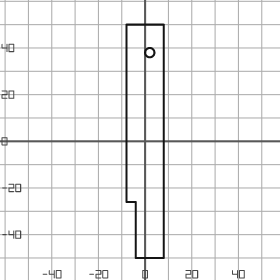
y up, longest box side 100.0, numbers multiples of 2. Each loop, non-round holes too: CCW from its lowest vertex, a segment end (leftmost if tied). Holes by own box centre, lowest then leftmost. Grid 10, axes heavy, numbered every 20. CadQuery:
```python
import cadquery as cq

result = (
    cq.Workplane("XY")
    .moveTo(-4.0, -50.0)
    .lineTo(8.0, -50.0)
    .lineTo(8.0, 50.0)
    .lineTo(-8.0, 50.0)
    .lineTo(-8.0, -26.0)
    .lineTo(-4.0, -26.0)
    .close()
    .moveTo(2.0, 38.0)
    .circle(2.0)
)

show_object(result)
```